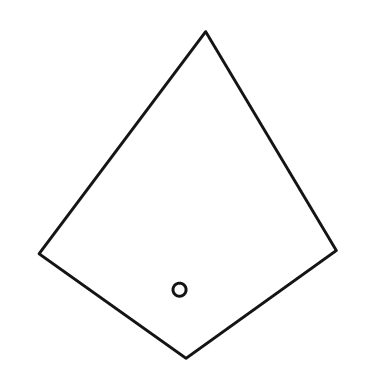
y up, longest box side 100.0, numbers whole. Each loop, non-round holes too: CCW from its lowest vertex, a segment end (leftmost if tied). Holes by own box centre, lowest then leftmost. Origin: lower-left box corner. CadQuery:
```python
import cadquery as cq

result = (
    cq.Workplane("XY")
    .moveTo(45.0, 0.0)
    .lineTo(91.0, 33.0)
    .lineTo(51.0, 100.0)
    .lineTo(0.0, 32.0)
    .close()
    .moveTo(43.0, 21.0)
    .circle(2.0)
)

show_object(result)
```